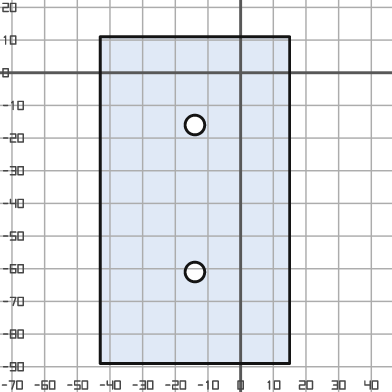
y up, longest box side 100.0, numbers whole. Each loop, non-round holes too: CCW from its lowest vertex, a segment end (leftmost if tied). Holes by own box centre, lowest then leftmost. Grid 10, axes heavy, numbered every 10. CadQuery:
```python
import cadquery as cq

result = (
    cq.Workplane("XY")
    .moveTo(-43.0, -89.0)
    .lineTo(15.0, -89.0)
    .lineTo(15.0, 11.0)
    .lineTo(-43.0, 11.0)
    .close()
    .moveTo(-14.0, -61.0)
    .circle(3.0)
    .moveTo(-14.0, -16.0)
    .circle(3.0)
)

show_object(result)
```